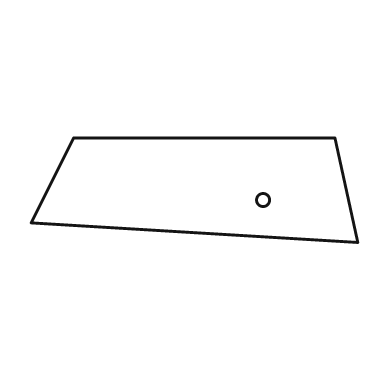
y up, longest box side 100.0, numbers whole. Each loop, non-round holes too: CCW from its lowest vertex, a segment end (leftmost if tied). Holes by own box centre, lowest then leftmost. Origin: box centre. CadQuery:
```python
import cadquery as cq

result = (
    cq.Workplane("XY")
    .moveTo(50.0, -16.0)
    .lineTo(43.0, 16.0)
    .lineTo(-37.0, 16.0)
    .lineTo(-50.0, -10.0)
    .close()
    .moveTo(21.0, -3.0)
    .circle(2.0)
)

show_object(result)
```